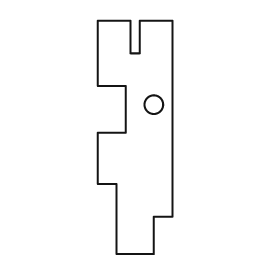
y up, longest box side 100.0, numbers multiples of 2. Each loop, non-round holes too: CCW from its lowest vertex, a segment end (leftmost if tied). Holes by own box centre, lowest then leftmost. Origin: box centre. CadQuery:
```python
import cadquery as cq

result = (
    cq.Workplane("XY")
    .moveTo(-8.0, -50.0)
    .lineTo(8.0, -50.0)
    .lineTo(8.0, -34.0)
    .lineTo(16.0, -34.0)
    .lineTo(16.0, 50.0)
    .lineTo(2.0, 50.0)
    .lineTo(2.0, 36.0)
    .lineTo(-2.0, 36.0)
    .lineTo(-2.0, 50.0)
    .lineTo(-16.0, 50.0)
    .lineTo(-16.0, 22.0)
    .lineTo(-4.0, 22.0)
    .lineTo(-4.0, 2.0)
    .lineTo(-16.0, 2.0)
    .lineTo(-16.0, -20.0)
    .lineTo(-8.0, -20.0)
    .close()
    .moveTo(8.0, 14.0)
    .circle(4.0)
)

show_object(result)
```